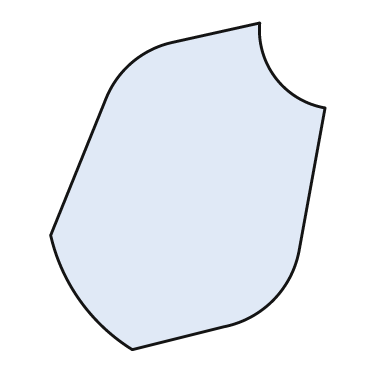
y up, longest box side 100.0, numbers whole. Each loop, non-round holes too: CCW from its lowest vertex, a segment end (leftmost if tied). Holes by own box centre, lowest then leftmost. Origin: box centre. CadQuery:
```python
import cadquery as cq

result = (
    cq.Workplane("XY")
    .moveTo(-17.0, -50.0)
    .lineTo(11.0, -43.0)
    .threePointArc((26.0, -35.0), (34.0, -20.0))
    .lineTo(42.0, 24.0)
    .threePointArc((27.0, 33.0), (22.0, 50.0))
    .lineTo(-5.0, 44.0)
    .threePointArc((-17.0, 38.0), (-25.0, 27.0))
    .lineTo(-42.0, -15.0)
    .threePointArc((-33.0, -35.0), (-17.0, -50.0))
    .close()
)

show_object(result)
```